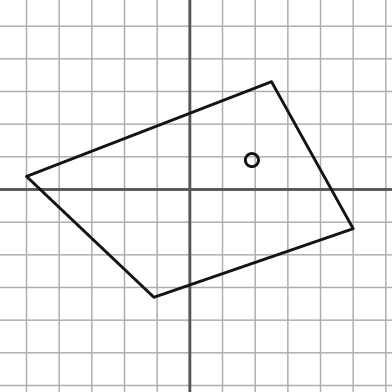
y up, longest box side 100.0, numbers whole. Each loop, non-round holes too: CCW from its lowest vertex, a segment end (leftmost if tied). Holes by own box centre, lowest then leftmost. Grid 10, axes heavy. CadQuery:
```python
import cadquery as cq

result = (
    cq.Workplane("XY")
    .moveTo(-11.0, -33.0)
    .lineTo(50.0, -12.0)
    .lineTo(25.0, 33.0)
    .lineTo(-50.0, 4.0)
    .close()
    .moveTo(19.0, 9.0)
    .circle(2.0)
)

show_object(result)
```